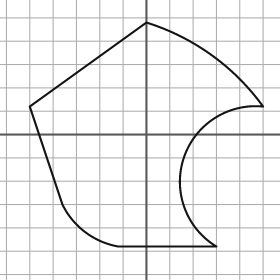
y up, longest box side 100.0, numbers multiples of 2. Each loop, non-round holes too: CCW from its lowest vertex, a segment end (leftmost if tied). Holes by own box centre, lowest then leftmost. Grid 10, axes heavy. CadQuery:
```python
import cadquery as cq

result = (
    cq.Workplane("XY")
    .moveTo(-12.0, -48.0)
    .lineTo(30.0, -48.0)
    .threePointArc((16.0, -10.0), (50.0, 12.0))
    .threePointArc((28.0, 34.0), (0.0, 48.0))
    .lineTo(-50.0, 12.0)
    .lineTo(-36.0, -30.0)
    .threePointArc((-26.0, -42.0), (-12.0, -48.0))
    .close()
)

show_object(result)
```